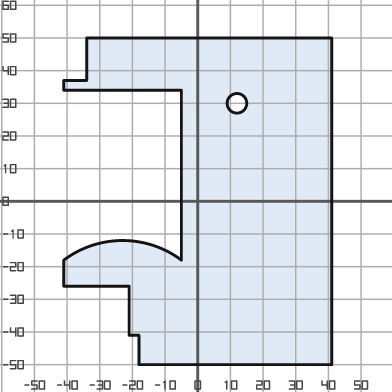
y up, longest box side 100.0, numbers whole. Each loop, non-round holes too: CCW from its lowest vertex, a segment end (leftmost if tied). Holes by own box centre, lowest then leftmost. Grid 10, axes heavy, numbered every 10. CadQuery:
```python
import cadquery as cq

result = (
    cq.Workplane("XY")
    .moveTo(-18.0, -50.0)
    .lineTo(41.0, -50.0)
    .lineTo(41.0, 50.0)
    .lineTo(-34.0, 50.0)
    .lineTo(-34.0, 37.0)
    .lineTo(-41.0, 37.0)
    .lineTo(-41.0, 34.0)
    .lineTo(-5.0, 34.0)
    .lineTo(-5.0, -18.0)
    .threePointArc((-23.0, -12.0), (-41.0, -18.0))
    .lineTo(-41.0, -26.0)
    .lineTo(-21.0, -26.0)
    .lineTo(-21.0, -41.0)
    .lineTo(-18.0, -41.0)
    .close()
    .moveTo(12.0, 30.0)
    .circle(3.0)
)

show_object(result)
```